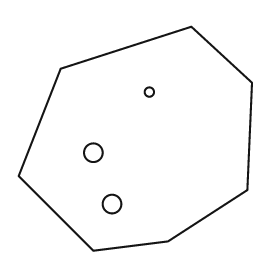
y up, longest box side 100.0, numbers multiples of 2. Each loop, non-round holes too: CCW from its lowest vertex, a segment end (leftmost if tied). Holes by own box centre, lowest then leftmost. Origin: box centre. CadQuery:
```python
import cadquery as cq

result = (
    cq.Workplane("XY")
    .moveTo(-18.0, -48.0)
    .lineTo(14.0, -44.0)
    .lineTo(48.0, -22.0)
    .lineTo(50.0, 24.0)
    .lineTo(24.0, 48.0)
    .lineTo(-32.0, 30.0)
    .lineTo(-50.0, -16.0)
    .close()
    .moveTo(-10.0, -28.0)
    .circle(4.0)
    .moveTo(-18.0, -6.0)
    .circle(4.0)
    .moveTo(6.0, 20.0)
    .circle(2.0)
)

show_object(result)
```